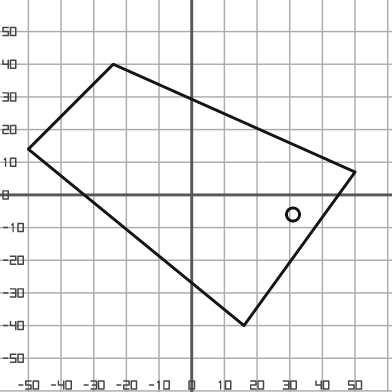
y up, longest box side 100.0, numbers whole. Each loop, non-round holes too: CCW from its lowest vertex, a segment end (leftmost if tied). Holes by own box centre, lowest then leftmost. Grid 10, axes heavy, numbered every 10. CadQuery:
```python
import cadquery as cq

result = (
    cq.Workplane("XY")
    .moveTo(16.0, -40.0)
    .lineTo(50.0, 7.0)
    .lineTo(-24.0, 40.0)
    .lineTo(-50.0, 14.0)
    .close()
    .moveTo(31.0, -6.0)
    .circle(2.0)
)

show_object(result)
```